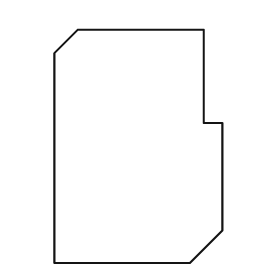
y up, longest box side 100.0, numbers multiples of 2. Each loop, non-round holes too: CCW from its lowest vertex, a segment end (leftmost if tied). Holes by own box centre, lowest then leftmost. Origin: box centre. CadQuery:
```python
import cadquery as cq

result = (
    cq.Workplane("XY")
    .moveTo(-36.0, -50.0)
    .lineTo(22.0, -50.0)
    .lineTo(36.0, -36.0)
    .lineTo(36.0, 10.0)
    .lineTo(28.0, 10.0)
    .lineTo(28.0, 50.0)
    .lineTo(-26.0, 50.0)
    .lineTo(-36.0, 40.0)
    .close()
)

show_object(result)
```